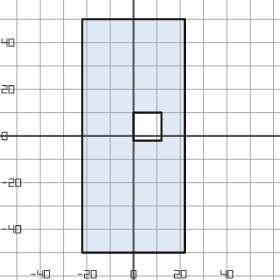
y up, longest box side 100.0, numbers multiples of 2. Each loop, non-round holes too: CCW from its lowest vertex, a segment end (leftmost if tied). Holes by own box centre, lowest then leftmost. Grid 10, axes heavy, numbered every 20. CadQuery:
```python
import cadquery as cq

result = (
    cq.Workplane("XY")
    .moveTo(-22.0, -50.0)
    .lineTo(22.0, -50.0)
    .lineTo(22.0, 50.0)
    .lineTo(-22.0, 50.0)
    .close()
    .moveTo(0.0, -2.0)
    .lineTo(12.0, -2.0)
    .lineTo(12.0, 10.0)
    .lineTo(0.0, 10.0)
    .close()
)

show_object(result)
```